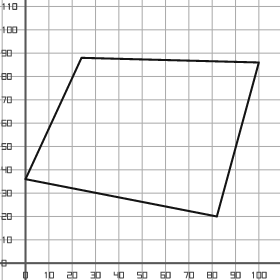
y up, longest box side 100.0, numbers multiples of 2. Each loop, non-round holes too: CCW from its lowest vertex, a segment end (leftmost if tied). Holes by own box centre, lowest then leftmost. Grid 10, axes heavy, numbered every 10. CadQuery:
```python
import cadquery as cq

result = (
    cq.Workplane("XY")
    .moveTo(82.0, 20.0)
    .lineTo(100.0, 86.0)
    .lineTo(24.0, 88.0)
    .lineTo(0.0, 36.0)
    .close()
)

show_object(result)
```